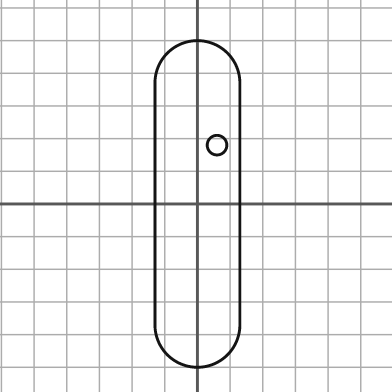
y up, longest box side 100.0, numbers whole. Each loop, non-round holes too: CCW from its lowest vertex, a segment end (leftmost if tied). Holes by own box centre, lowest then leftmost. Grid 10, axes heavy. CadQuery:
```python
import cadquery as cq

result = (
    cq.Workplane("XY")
    .moveTo(-13.0, -37.0)
    .threePointArc((0.0, -50.0), (13.0, -37.0))
    .lineTo(13.0, 37.0)
    .threePointArc((0.0, 50.0), (-13.0, 37.0))
    .close()
    .moveTo(6.0, 18.0)
    .circle(3.0)
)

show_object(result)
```